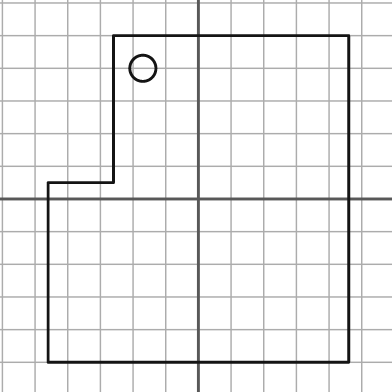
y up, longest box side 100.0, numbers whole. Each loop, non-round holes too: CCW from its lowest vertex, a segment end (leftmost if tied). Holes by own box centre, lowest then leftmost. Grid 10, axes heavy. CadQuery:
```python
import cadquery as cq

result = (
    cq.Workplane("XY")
    .moveTo(-46.0, -50.0)
    .lineTo(46.0, -50.0)
    .lineTo(46.0, 50.0)
    .lineTo(-26.0, 50.0)
    .lineTo(-26.0, 5.0)
    .lineTo(-46.0, 5.0)
    .close()
    .moveTo(-17.0, 40.0)
    .circle(4.0)
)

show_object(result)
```